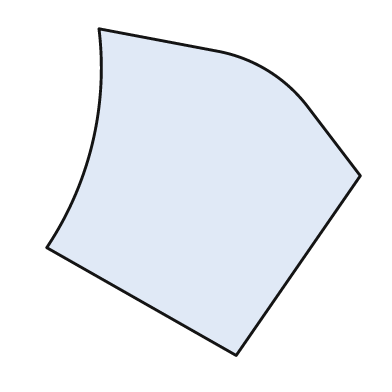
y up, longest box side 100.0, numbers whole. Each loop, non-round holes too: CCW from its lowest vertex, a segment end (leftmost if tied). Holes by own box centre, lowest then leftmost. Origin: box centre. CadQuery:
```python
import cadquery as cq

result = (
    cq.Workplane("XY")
    .moveTo(10.0, -50.0)
    .lineTo(48.0, 5.0)
    .lineTo(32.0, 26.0)
    .threePointArc((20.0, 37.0), (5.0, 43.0))
    .lineTo(-32.0, 50.0)
    .threePointArc((-34.0, 15.0), (-48.0, -17.0))
    .close()
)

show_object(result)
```